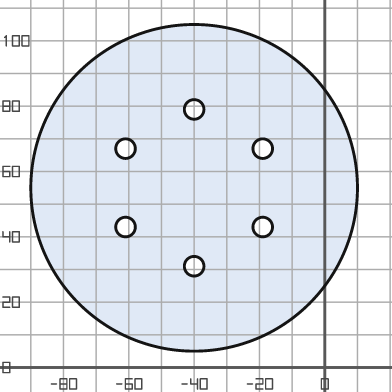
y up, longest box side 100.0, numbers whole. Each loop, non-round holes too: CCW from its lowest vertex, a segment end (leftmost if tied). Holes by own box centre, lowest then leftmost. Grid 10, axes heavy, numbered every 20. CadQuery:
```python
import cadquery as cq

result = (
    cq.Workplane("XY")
    .moveTo(-40.0, 55.0)
    .circle(50.0)
    .moveTo(-40.0, 31.0)
    .circle(3.0)
    .moveTo(-61.0, 43.0)
    .circle(3.0)
    .moveTo(-19.0, 43.0)
    .circle(3.0)
    .moveTo(-61.0, 67.0)
    .circle(3.0)
    .moveTo(-19.0, 67.0)
    .circle(3.0)
    .moveTo(-40.0, 79.0)
    .circle(3.0)
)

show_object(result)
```